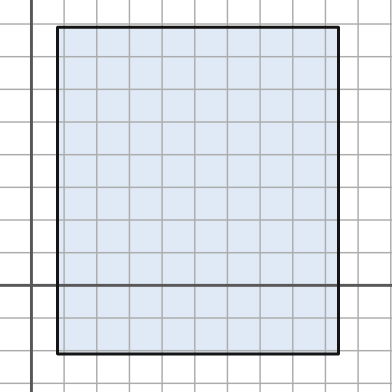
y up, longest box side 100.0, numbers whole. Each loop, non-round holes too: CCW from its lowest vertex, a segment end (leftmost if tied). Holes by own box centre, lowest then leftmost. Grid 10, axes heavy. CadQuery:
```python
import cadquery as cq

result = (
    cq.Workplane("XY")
    .moveTo(8.0, -21.0)
    .lineTo(94.0, -21.0)
    .lineTo(94.0, 79.0)
    .lineTo(8.0, 79.0)
    .close()
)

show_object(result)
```